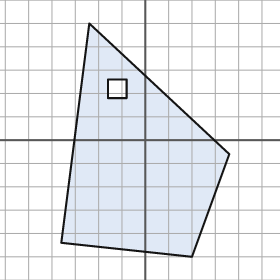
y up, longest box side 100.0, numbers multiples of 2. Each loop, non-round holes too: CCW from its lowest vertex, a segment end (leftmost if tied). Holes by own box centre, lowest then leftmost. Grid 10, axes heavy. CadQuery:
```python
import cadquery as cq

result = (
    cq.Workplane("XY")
    .moveTo(20.0, -50.0)
    .lineTo(36.0, -6.0)
    .lineTo(-24.0, 50.0)
    .lineTo(-36.0, -44.0)
    .close()
    .moveTo(-16.0, 18.0)
    .lineTo(-8.0, 18.0)
    .lineTo(-8.0, 26.0)
    .lineTo(-16.0, 26.0)
    .close()
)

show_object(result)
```